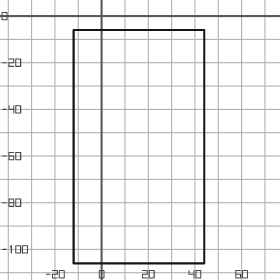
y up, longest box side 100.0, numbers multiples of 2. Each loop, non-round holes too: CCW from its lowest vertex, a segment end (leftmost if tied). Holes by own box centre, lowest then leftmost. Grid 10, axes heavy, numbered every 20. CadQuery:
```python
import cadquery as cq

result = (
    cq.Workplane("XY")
    .moveTo(-12.0, -106.0)
    .lineTo(44.0, -106.0)
    .lineTo(44.0, -6.0)
    .lineTo(-12.0, -6.0)
    .close()
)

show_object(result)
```